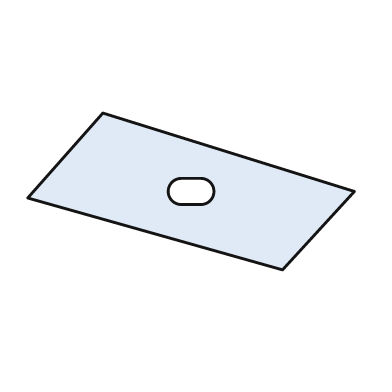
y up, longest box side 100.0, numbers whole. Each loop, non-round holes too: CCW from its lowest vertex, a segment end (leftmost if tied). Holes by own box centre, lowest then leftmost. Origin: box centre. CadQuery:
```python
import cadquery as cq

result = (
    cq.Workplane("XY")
    .moveTo(28.0, -24.0)
    .lineTo(50.0, 0.0)
    .lineTo(-27.0, 24.0)
    .lineTo(-50.0, -2.0)
    .close()
    .moveTo(-3.0, -4.0)
    .lineTo(3.0, -4.0)
    .threePointArc((7.0, 0.0), (3.0, 4.0))
    .lineTo(-3.0, 4.0)
    .threePointArc((-7.0, 0.0), (-3.0, -4.0))
    .close()
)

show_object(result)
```